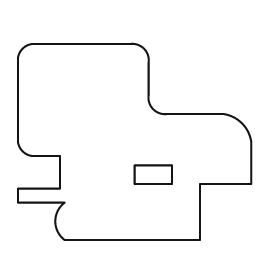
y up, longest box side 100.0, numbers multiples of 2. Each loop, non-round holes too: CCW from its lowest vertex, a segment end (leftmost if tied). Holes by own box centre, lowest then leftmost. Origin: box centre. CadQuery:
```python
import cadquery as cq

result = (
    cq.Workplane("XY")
    .moveTo(-30.0, -42.0)
    .lineTo(28.0, -42.0)
    .lineTo(28.0, -18.0)
    .lineTo(50.0, -18.0)
    .lineTo(50.0, 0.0)
    .threePointArc((46.0, 8.0), (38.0, 12.0))
    .lineTo(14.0, 12.0)
    .threePointArc((8.0, 14.0), (6.0, 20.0))
    .lineTo(6.0, 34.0)
    .threePointArc((4.0, 40.0), (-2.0, 42.0))
    .lineTo(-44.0, 42.0)
    .threePointArc((-48.0, 40.0), (-50.0, 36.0))
    .lineTo(-50.0, 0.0)
    .threePointArc((-48.0, -4.0), (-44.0, -6.0))
    .lineTo(-32.0, -6.0)
    .lineTo(-32.0, -20.0)
    .lineTo(-50.0, -20.0)
    .lineTo(-50.0, -26.0)
    .lineTo(-30.0, -26.0)
    .threePointArc((-34.0, -34.0), (-30.0, -42.0))
    .close()
    .moveTo(0.0, -18.0)
    .lineTo(16.0, -18.0)
    .lineTo(16.0, -10.0)
    .lineTo(0.0, -10.0)
    .close()
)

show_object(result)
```